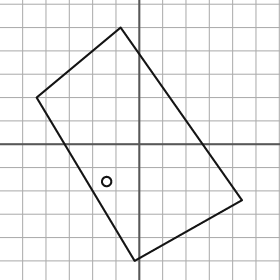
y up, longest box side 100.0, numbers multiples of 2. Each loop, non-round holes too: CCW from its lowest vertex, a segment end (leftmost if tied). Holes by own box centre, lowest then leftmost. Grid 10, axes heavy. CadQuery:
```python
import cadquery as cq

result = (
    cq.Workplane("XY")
    .moveTo(-2.0, -50.0)
    .lineTo(44.0, -24.0)
    .lineTo(-8.0, 50.0)
    .lineTo(-44.0, 20.0)
    .close()
    .moveTo(-14.0, -16.0)
    .circle(2.0)
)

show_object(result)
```